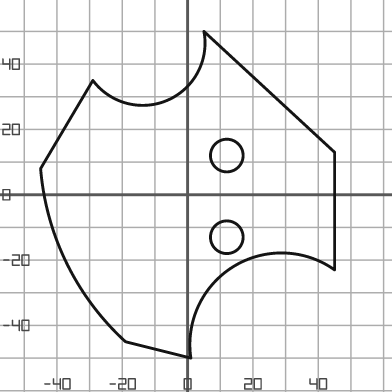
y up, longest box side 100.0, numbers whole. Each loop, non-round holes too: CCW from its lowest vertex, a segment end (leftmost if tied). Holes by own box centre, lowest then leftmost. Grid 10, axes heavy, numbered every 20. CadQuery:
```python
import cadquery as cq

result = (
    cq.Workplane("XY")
    .moveTo(1.0, -50.0)
    .threePointArc((14.0, -22.0), (45.0, -23.0))
    .lineTo(45.0, 13.0)
    .lineTo(5.0, 50.0)
    .threePointArc((-6.0, 29.0), (-29.0, 35.0))
    .lineTo(-45.0, 8.0)
    .threePointArc((-37.0, -21.0), (-19.0, -45.0))
    .close()
    .moveTo(12.0, -13.0)
    .circle(5.0)
    .moveTo(12.0, 12.0)
    .circle(5.0)
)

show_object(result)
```